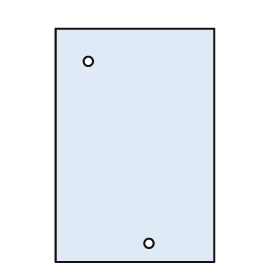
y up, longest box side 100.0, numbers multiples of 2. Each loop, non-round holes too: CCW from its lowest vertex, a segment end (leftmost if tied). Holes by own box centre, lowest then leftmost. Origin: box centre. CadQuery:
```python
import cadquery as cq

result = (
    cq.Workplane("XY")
    .moveTo(-34.0, -50.0)
    .lineTo(34.0, -50.0)
    .lineTo(34.0, 50.0)
    .lineTo(-34.0, 50.0)
    .close()
    .moveTo(6.0, -42.0)
    .circle(2.0)
    .moveTo(-20.0, 36.0)
    .circle(2.0)
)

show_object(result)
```